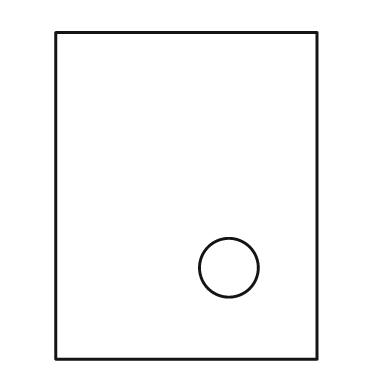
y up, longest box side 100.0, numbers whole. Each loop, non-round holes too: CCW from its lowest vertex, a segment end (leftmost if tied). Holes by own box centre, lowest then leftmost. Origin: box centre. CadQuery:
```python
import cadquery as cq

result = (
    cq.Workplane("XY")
    .moveTo(-40.0, -50.0)
    .lineTo(40.0, -50.0)
    .lineTo(40.0, 50.0)
    .lineTo(-40.0, 50.0)
    .close()
    .moveTo(13.0, -22.0)
    .circle(9.0)
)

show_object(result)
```